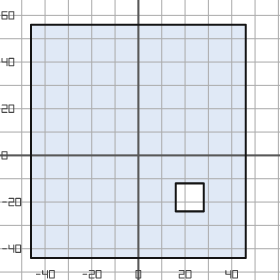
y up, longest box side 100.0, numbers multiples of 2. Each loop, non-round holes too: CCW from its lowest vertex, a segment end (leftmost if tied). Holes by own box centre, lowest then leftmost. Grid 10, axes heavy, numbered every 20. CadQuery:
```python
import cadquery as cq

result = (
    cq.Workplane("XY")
    .moveTo(-46.0, -44.0)
    .lineTo(46.0, -44.0)
    .lineTo(46.0, 56.0)
    .lineTo(-46.0, 56.0)
    .close()
    .moveTo(16.0, -24.0)
    .lineTo(28.0, -24.0)
    .lineTo(28.0, -12.0)
    .lineTo(16.0, -12.0)
    .close()
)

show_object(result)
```